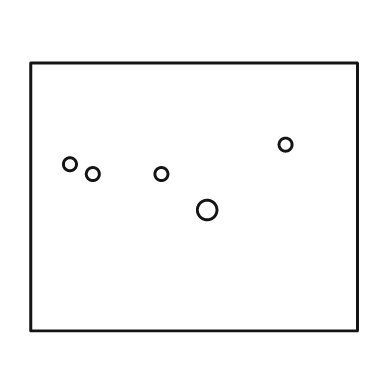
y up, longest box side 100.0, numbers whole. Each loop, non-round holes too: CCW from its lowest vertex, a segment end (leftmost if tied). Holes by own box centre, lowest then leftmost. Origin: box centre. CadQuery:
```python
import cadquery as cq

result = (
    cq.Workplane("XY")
    .moveTo(-50.0, -41.0)
    .lineTo(50.0, -41.0)
    .lineTo(50.0, 41.0)
    .lineTo(-50.0, 41.0)
    .close()
    .moveTo(4.0, -4.0)
    .circle(3.0)
    .moveTo(-31.0, 7.0)
    .circle(2.0)
    .moveTo(-10.0, 7.0)
    .circle(2.0)
    .moveTo(-38.0, 10.0)
    .circle(2.0)
    .moveTo(28.0, 16.0)
    .circle(2.0)
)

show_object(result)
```